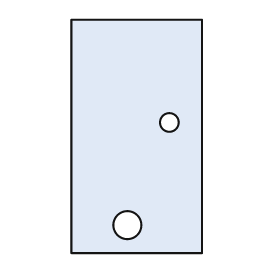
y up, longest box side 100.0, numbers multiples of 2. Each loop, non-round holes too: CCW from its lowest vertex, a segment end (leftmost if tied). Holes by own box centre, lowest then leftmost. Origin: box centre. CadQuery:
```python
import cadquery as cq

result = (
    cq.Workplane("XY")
    .moveTo(-28.0, -50.0)
    .lineTo(28.0, -50.0)
    .lineTo(28.0, 50.0)
    .lineTo(-28.0, 50.0)
    .close()
    .moveTo(-4.0, -38.0)
    .circle(6.0)
    .moveTo(14.0, 6.0)
    .circle(4.0)
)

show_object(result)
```